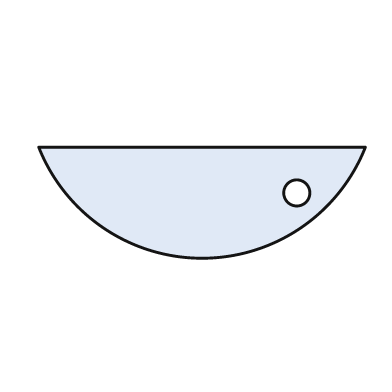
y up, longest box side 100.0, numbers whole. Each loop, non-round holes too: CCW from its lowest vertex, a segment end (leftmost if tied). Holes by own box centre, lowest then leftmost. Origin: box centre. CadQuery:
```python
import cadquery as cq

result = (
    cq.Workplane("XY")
    .moveTo(-50.0, 17.0)
    .threePointArc((0.0, -17.0), (50.0, 17.0))
    .close()
    .moveTo(29.0, 3.0)
    .circle(4.0)
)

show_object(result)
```